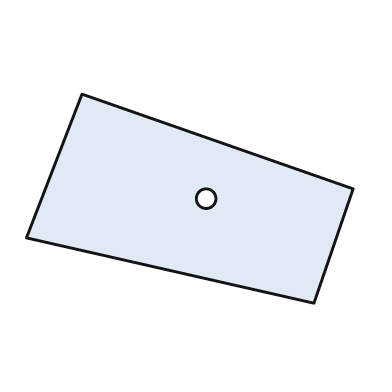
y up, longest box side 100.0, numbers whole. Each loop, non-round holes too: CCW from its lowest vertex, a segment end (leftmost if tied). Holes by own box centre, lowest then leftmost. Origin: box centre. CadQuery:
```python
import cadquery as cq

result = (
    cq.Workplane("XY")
    .moveTo(38.0, -32.0)
    .lineTo(50.0, 3.0)
    .lineTo(-33.0, 32.0)
    .lineTo(-50.0, -12.0)
    .close()
    .moveTo(5.0, 0.0)
    .circle(3.0)
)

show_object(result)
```